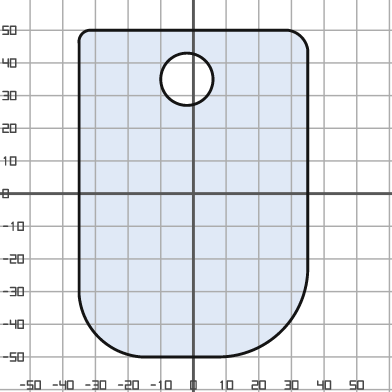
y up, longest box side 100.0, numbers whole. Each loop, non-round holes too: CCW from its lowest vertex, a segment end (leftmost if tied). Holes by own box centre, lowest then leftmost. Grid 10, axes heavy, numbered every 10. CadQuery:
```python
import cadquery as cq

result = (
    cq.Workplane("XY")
    .moveTo(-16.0, -50.0)
    .lineTo(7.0, -50.0)
    .threePointArc((27.0, -42.0), (35.0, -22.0))
    .lineTo(35.0, 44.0)
    .threePointArc((33.0, 48.0), (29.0, 50.0))
    .lineTo(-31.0, 50.0)
    .threePointArc((-34.0, 49.0), (-35.0, 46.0))
    .lineTo(-35.0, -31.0)
    .threePointArc((-29.0, -44.0), (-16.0, -50.0))
    .close()
    .moveTo(-2.0, 35.0)
    .circle(8.0)
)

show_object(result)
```